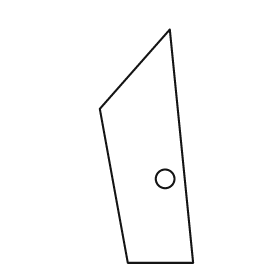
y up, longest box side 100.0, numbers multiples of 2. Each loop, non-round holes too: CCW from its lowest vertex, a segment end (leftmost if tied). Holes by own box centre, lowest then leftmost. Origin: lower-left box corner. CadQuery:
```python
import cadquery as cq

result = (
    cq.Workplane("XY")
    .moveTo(12.0, 0.0)
    .lineTo(40.0, 0.0)
    .lineTo(30.0, 100.0)
    .lineTo(0.0, 66.0)
    .close()
    .moveTo(28.0, 36.0)
    .circle(4.0)
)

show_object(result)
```